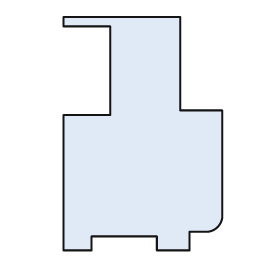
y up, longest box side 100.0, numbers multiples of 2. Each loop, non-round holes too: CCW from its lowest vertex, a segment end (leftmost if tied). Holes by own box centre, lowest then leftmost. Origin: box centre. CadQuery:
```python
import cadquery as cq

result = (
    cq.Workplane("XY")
    .moveTo(-34.0, -50.0)
    .lineTo(-22.0, -50.0)
    .lineTo(-22.0, -44.0)
    .lineTo(6.0, -44.0)
    .lineTo(6.0, -50.0)
    .lineTo(20.0, -50.0)
    .lineTo(20.0, -42.0)
    .lineTo(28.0, -42.0)
    .threePointArc((32.0, -40.0), (34.0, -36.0))
    .lineTo(34.0, 10.0)
    .lineTo(16.0, 10.0)
    .lineTo(16.0, 50.0)
    .lineTo(-34.0, 50.0)
    .lineTo(-34.0, 46.0)
    .lineTo(-14.0, 46.0)
    .lineTo(-14.0, 8.0)
    .lineTo(-34.0, 8.0)
    .close()
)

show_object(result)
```